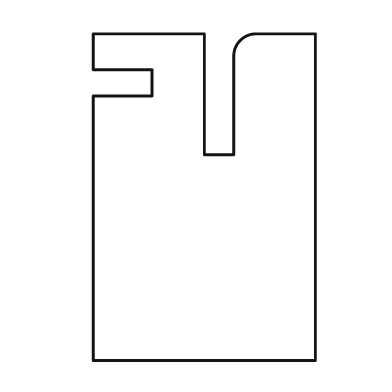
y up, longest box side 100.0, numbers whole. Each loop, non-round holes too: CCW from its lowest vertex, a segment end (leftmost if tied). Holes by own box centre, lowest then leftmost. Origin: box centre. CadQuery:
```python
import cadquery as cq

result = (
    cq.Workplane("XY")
    .moveTo(-34.0, -50.0)
    .lineTo(34.0, -50.0)
    .lineTo(34.0, 50.0)
    .lineTo(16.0, 50.0)
    .threePointArc((11.0, 48.0), (9.0, 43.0))
    .lineTo(9.0, 13.0)
    .lineTo(0.0, 13.0)
    .lineTo(0.0, 50.0)
    .lineTo(-34.0, 50.0)
    .lineTo(-34.0, 39.0)
    .lineTo(-16.0, 39.0)
    .lineTo(-16.0, 31.0)
    .lineTo(-34.0, 31.0)
    .close()
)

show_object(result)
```